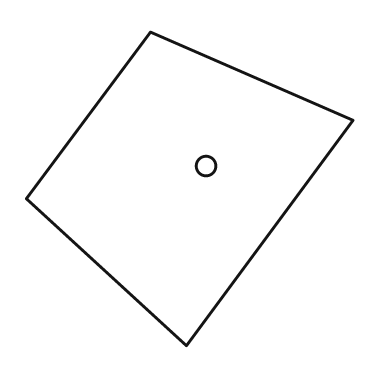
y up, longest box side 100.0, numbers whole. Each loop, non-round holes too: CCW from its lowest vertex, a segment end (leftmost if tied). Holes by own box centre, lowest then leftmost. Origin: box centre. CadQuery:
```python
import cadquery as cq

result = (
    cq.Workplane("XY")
    .moveTo(-1.0, -48.0)
    .lineTo(50.0, 21.0)
    .lineTo(-12.0, 48.0)
    .lineTo(-50.0, -3.0)
    .close()
    .moveTo(5.0, 7.0)
    .circle(3.0)
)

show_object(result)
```